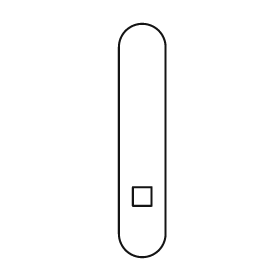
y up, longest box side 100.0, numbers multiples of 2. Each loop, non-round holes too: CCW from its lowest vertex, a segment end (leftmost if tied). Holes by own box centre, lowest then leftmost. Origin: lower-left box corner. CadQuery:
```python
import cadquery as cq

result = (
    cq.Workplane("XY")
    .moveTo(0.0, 10.0)
    .threePointArc((10.0, 0.0), (20.0, 10.0))
    .lineTo(20.0, 90.0)
    .threePointArc((10.0, 100.0), (0.0, 90.0))
    .close()
    .moveTo(6.0, 22.0)
    .lineTo(14.0, 22.0)
    .lineTo(14.0, 30.0)
    .lineTo(6.0, 30.0)
    .close()
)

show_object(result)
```